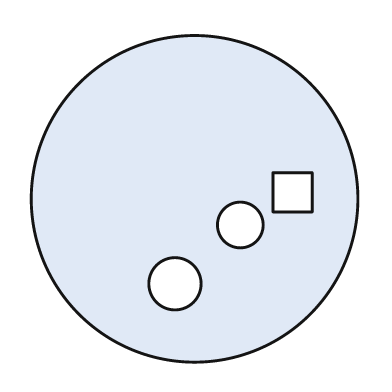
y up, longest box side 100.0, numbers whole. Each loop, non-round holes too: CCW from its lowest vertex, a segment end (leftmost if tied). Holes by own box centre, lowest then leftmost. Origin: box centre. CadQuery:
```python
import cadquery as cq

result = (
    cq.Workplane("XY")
    .moveTo(0.0, 0.0)
    .circle(50.0)
    .moveTo(-6.0, -26.0)
    .circle(8.0)
    .moveTo(14.0, -8.0)
    .circle(7.0)
    .moveTo(24.0, -4.0)
    .lineTo(36.0, -4.0)
    .lineTo(36.0, 8.0)
    .lineTo(24.0, 8.0)
    .close()
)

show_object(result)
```